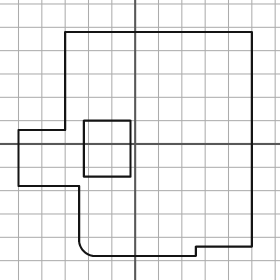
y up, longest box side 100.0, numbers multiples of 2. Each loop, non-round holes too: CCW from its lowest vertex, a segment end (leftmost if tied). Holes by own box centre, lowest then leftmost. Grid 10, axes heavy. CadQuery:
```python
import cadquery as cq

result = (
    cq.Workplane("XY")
    .moveTo(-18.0, -48.0)
    .lineTo(26.0, -48.0)
    .lineTo(26.0, -44.0)
    .lineTo(50.0, -44.0)
    .lineTo(50.0, 48.0)
    .lineTo(-30.0, 48.0)
    .lineTo(-30.0, 6.0)
    .lineTo(-50.0, 6.0)
    .lineTo(-50.0, -18.0)
    .lineTo(-24.0, -18.0)
    .lineTo(-24.0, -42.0)
    .threePointArc((-22.0, -46.0), (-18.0, -48.0))
    .close()
    .moveTo(-22.0, -14.0)
    .lineTo(-2.0, -14.0)
    .lineTo(-2.0, 10.0)
    .lineTo(-22.0, 10.0)
    .close()
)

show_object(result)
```